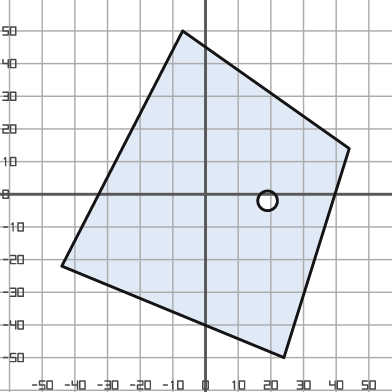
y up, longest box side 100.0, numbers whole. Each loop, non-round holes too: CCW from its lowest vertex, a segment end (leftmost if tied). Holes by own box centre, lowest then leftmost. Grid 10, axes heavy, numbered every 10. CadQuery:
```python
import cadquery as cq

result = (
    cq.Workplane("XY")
    .moveTo(24.0, -50.0)
    .lineTo(44.0, 14.0)
    .lineTo(-7.0, 50.0)
    .lineTo(-44.0, -22.0)
    .close()
    .moveTo(19.0, -2.0)
    .circle(3.0)
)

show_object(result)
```